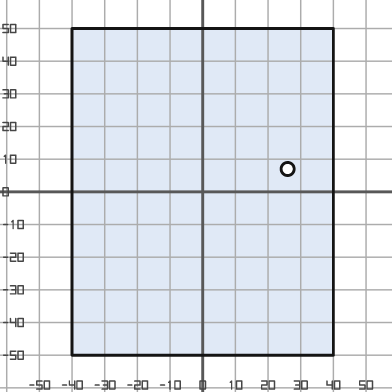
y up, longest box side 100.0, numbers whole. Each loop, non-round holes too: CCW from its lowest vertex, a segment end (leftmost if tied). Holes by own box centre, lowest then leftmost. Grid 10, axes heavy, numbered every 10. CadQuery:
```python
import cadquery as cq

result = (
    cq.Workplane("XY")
    .moveTo(-40.0, -50.0)
    .lineTo(40.0, -50.0)
    .lineTo(40.0, 50.0)
    .lineTo(-40.0, 50.0)
    .close()
    .moveTo(26.0, 7.0)
    .circle(2.0)
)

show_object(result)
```